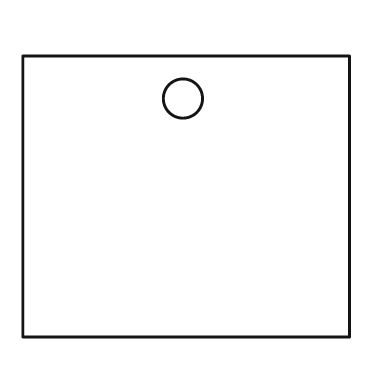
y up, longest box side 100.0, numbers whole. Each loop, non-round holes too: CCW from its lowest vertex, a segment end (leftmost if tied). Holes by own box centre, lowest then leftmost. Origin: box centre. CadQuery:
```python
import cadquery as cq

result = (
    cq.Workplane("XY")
    .moveTo(-50.0, -43.0)
    .lineTo(50.0, -43.0)
    .lineTo(50.0, 43.0)
    .lineTo(-50.0, 43.0)
    .close()
    .moveTo(-1.0, 30.0)
    .circle(6.0)
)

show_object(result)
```